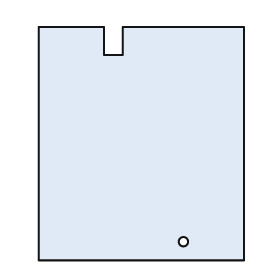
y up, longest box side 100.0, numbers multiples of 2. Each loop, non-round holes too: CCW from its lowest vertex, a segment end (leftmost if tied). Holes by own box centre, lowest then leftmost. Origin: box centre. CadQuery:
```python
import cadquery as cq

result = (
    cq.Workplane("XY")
    .moveTo(-44.0, -50.0)
    .lineTo(44.0, -50.0)
    .lineTo(44.0, 50.0)
    .lineTo(-8.0, 50.0)
    .lineTo(-8.0, 38.0)
    .lineTo(-16.0, 38.0)
    .lineTo(-16.0, 50.0)
    .lineTo(-44.0, 50.0)
    .close()
    .moveTo(18.0, -42.0)
    .circle(2.0)
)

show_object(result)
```